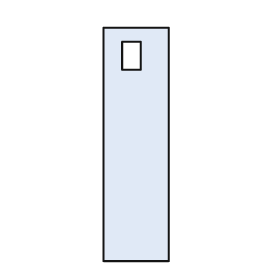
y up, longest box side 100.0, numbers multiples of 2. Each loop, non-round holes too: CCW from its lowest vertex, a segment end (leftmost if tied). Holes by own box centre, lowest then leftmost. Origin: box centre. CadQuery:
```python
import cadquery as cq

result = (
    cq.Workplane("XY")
    .moveTo(-14.0, -50.0)
    .lineTo(14.0, -50.0)
    .lineTo(14.0, 50.0)
    .lineTo(-14.0, 50.0)
    .close()
    .moveTo(-6.0, 32.0)
    .lineTo(2.0, 32.0)
    .lineTo(2.0, 44.0)
    .lineTo(-6.0, 44.0)
    .close()
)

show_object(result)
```